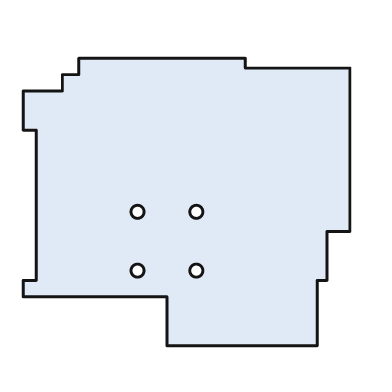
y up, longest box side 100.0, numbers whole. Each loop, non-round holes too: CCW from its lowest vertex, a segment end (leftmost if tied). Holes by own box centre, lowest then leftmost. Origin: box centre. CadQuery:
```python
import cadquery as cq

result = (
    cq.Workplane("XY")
    .moveTo(-6.0, -44.0)
    .lineTo(40.0, -44.0)
    .lineTo(40.0, -24.0)
    .lineTo(43.0, -24.0)
    .lineTo(43.0, -9.0)
    .lineTo(50.0, -9.0)
    .lineTo(50.0, 41.0)
    .lineTo(18.0, 41.0)
    .lineTo(18.0, 44.0)
    .lineTo(-33.0, 44.0)
    .lineTo(-33.0, 39.0)
    .lineTo(-38.0, 39.0)
    .lineTo(-38.0, 34.0)
    .lineTo(-50.0, 34.0)
    .lineTo(-50.0, 22.0)
    .lineTo(-46.0, 22.0)
    .lineTo(-46.0, -24.0)
    .lineTo(-50.0, -24.0)
    .lineTo(-50.0, -29.0)
    .lineTo(-6.0, -29.0)
    .close()
    .moveTo(-15.0, -21.0)
    .circle(2.0)
    .moveTo(3.0, -21.0)
    .circle(2.0)
    .moveTo(-15.0, -3.0)
    .circle(2.0)
    .moveTo(3.0, -3.0)
    .circle(2.0)
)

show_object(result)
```